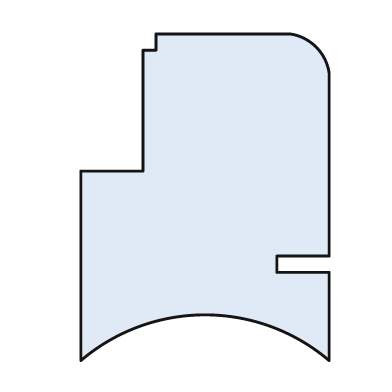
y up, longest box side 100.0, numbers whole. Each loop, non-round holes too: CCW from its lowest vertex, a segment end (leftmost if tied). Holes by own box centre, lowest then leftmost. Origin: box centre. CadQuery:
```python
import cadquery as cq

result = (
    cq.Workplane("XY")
    .moveTo(-38.0, -50.0)
    .threePointArc((0.0, -36.0), (38.0, -50.0))
    .lineTo(38.0, -23.0)
    .lineTo(22.0, -23.0)
    .lineTo(22.0, -18.0)
    .lineTo(38.0, -18.0)
    .lineTo(38.0, 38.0)
    .threePointArc((34.0, 46.0), (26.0, 50.0))
    .lineTo(-15.0, 50.0)
    .lineTo(-15.0, 45.0)
    .lineTo(-19.0, 45.0)
    .lineTo(-19.0, 8.0)
    .lineTo(-38.0, 8.0)
    .close()
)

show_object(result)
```